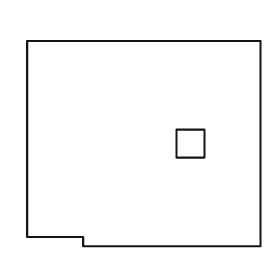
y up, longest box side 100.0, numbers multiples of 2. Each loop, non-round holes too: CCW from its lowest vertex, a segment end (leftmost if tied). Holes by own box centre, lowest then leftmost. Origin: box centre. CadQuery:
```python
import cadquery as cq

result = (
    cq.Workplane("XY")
    .moveTo(-26.0, -44.0)
    .lineTo(50.0, -44.0)
    .lineTo(50.0, 44.0)
    .lineTo(-50.0, 44.0)
    .lineTo(-50.0, -40.0)
    .lineTo(-26.0, -40.0)
    .close()
    .moveTo(14.0, -6.0)
    .lineTo(26.0, -6.0)
    .lineTo(26.0, 6.0)
    .lineTo(14.0, 6.0)
    .close()
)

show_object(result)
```